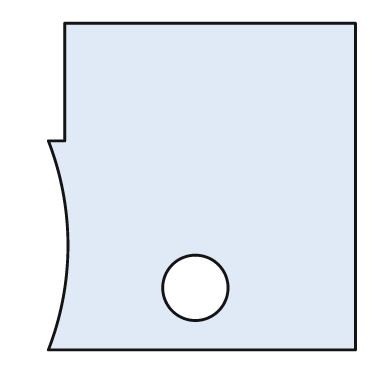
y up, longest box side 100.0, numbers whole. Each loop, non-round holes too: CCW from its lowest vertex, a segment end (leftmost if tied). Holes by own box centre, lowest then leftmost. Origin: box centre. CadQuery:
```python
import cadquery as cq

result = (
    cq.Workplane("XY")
    .moveTo(-47.0, -50.0)
    .lineTo(47.0, -50.0)
    .lineTo(47.0, 50.0)
    .lineTo(-42.0, 50.0)
    .lineTo(-42.0, 14.0)
    .lineTo(-47.0, 14.0)
    .threePointArc((-41.0, -18.0), (-47.0, -50.0))
    .close()
    .moveTo(-2.0, -31.0)
    .circle(10.0)
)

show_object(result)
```